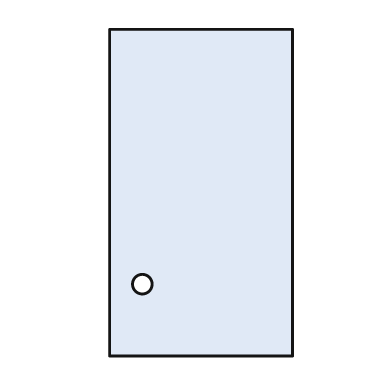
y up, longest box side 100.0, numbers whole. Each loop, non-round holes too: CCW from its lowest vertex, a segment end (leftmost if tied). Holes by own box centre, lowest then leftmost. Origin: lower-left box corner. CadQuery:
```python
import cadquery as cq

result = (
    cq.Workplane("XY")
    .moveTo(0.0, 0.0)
    .lineTo(56.0, 0.0)
    .lineTo(56.0, 100.0)
    .lineTo(0.0, 100.0)
    .close()
    .moveTo(10.0, 22.0)
    .circle(3.0)
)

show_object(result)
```